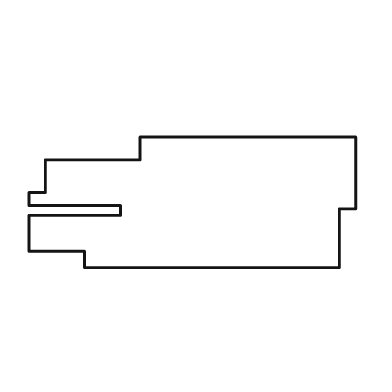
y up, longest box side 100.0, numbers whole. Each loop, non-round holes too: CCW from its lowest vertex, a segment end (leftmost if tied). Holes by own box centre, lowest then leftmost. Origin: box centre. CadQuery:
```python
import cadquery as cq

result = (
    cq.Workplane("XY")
    .moveTo(-33.0, -20.0)
    .lineTo(45.0, -20.0)
    .lineTo(45.0, -2.0)
    .lineTo(50.0, -2.0)
    .lineTo(50.0, 20.0)
    .lineTo(-16.0, 20.0)
    .lineTo(-16.0, 13.0)
    .lineTo(-45.0, 13.0)
    .lineTo(-45.0, 3.0)
    .lineTo(-50.0, 3.0)
    .lineTo(-50.0, -1.0)
    .lineTo(-22.0, -1.0)
    .lineTo(-22.0, -4.0)
    .lineTo(-50.0, -4.0)
    .lineTo(-50.0, -15.0)
    .lineTo(-33.0, -15.0)
    .close()
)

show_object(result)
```